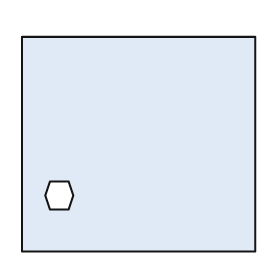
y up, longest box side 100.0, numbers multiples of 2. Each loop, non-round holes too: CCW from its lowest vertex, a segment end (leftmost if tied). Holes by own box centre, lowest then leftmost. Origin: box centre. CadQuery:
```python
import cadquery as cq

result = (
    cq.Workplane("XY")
    .moveTo(-50.0, -46.0)
    .lineTo(50.0, -46.0)
    .lineTo(50.0, 46.0)
    .lineTo(-50.0, 46.0)
    .close()
    .moveTo(-38.0, -28.0)
    .lineTo(-30.0, -28.0)
    .lineTo(-28.0, -22.0)
    .lineTo(-30.0, -16.0)
    .lineTo(-38.0, -16.0)
    .lineTo(-40.0, -22.0)
    .close()
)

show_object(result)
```